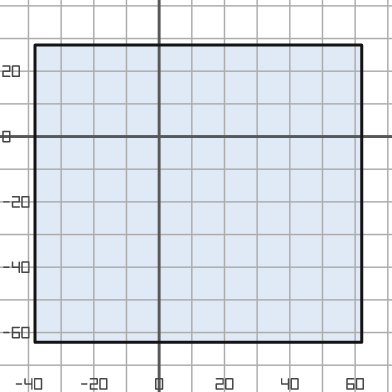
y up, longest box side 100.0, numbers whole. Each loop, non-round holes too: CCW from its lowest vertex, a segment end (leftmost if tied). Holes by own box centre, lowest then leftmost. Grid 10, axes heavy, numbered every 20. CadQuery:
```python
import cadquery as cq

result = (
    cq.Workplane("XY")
    .moveTo(-38.0, -63.0)
    .lineTo(62.0, -63.0)
    .lineTo(62.0, 28.0)
    .lineTo(-38.0, 28.0)
    .close()
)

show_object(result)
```